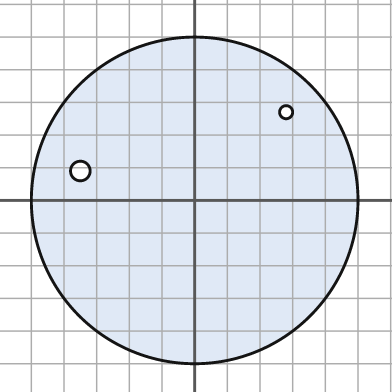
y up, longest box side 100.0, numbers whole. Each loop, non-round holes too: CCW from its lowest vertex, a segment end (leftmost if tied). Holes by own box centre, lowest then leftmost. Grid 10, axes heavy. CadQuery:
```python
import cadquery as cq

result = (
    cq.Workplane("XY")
    .moveTo(0.0, 0.0)
    .circle(50.0)
    .moveTo(-35.0, 9.0)
    .circle(3.0)
    .moveTo(28.0, 27.0)
    .circle(2.0)
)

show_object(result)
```